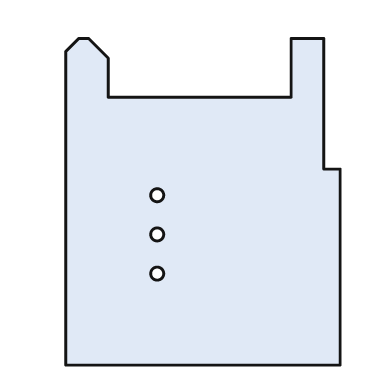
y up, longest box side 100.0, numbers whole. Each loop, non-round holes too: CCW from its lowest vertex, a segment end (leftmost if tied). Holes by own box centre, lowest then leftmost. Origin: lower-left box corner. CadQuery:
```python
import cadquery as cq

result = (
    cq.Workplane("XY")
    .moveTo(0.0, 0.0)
    .lineTo(84.0, 0.0)
    .lineTo(84.0, 60.0)
    .lineTo(79.0, 60.0)
    .lineTo(79.0, 100.0)
    .lineTo(69.0, 100.0)
    .lineTo(69.0, 82.0)
    .lineTo(13.0, 82.0)
    .lineTo(13.0, 94.0)
    .lineTo(7.0, 100.0)
    .lineTo(4.0, 100.0)
    .lineTo(0.0, 96.0)
    .close()
    .moveTo(28.0, 28.0)
    .circle(2.0)
    .moveTo(28.0, 40.0)
    .circle(2.0)
    .moveTo(28.0, 52.0)
    .circle(2.0)
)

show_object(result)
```